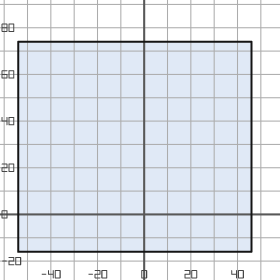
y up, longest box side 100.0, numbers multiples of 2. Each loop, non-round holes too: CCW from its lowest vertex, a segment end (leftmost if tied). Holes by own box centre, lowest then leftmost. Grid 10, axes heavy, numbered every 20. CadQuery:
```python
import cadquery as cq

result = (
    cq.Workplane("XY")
    .moveTo(-54.0, -16.0)
    .lineTo(46.0, -16.0)
    .lineTo(46.0, 74.0)
    .lineTo(-54.0, 74.0)
    .close()
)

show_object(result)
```